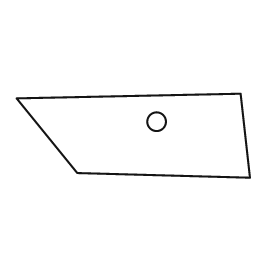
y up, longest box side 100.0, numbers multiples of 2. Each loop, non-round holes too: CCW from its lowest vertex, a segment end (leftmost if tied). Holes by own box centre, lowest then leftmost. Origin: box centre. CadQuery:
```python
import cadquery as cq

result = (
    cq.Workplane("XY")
    .moveTo(50.0, -18.0)
    .lineTo(46.0, 18.0)
    .lineTo(-50.0, 16.0)
    .lineTo(-24.0, -16.0)
    .close()
    .moveTo(10.0, 6.0)
    .circle(4.0)
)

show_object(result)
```